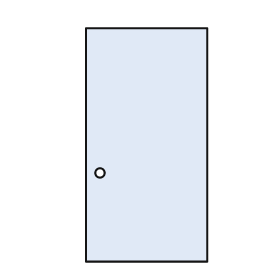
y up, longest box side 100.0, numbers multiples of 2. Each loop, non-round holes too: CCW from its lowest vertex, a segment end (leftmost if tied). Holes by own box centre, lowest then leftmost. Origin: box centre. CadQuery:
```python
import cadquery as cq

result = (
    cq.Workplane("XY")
    .moveTo(-26.0, -50.0)
    .lineTo(26.0, -50.0)
    .lineTo(26.0, 50.0)
    .lineTo(-26.0, 50.0)
    .close()
    .moveTo(-20.0, -12.0)
    .circle(2.0)
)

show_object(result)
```